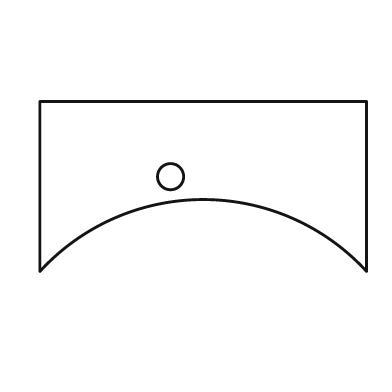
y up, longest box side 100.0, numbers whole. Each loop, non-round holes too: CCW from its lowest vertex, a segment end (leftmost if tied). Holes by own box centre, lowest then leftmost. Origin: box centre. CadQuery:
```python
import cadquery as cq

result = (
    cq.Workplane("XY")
    .moveTo(-50.0, -26.0)
    .threePointArc((0.0, -4.0), (50.0, -26.0))
    .lineTo(50.0, 26.0)
    .lineTo(-50.0, 26.0)
    .close()
    .moveTo(-10.0, 3.0)
    .circle(4.0)
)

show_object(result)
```